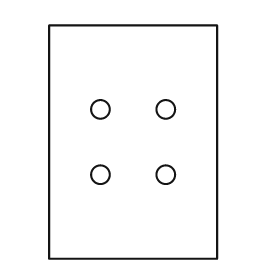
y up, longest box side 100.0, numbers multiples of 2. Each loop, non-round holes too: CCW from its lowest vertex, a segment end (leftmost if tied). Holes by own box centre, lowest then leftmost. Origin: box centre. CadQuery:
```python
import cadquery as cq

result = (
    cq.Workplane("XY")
    .moveTo(-36.0, -50.0)
    .lineTo(36.0, -50.0)
    .lineTo(36.0, 50.0)
    .lineTo(-36.0, 50.0)
    .close()
    .moveTo(-14.0, -14.0)
    .circle(4.0)
    .moveTo(14.0, -14.0)
    .circle(4.0)
    .moveTo(-14.0, 14.0)
    .circle(4.0)
    .moveTo(14.0, 14.0)
    .circle(4.0)
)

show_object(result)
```